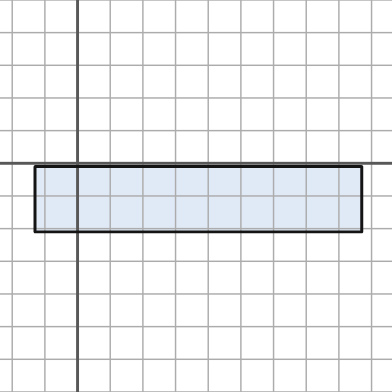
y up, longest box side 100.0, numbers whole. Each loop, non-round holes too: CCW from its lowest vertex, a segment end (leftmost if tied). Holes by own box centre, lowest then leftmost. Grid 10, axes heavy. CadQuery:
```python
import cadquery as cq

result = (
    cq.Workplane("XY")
    .moveTo(-13.0, -21.0)
    .lineTo(87.0, -21.0)
    .lineTo(87.0, -1.0)
    .lineTo(-13.0, -1.0)
    .close()
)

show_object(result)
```